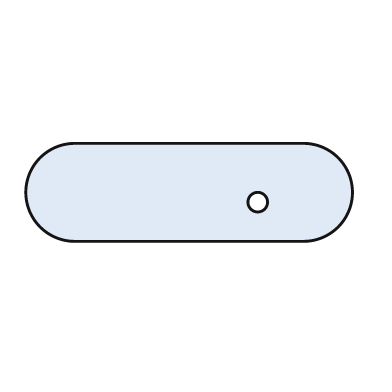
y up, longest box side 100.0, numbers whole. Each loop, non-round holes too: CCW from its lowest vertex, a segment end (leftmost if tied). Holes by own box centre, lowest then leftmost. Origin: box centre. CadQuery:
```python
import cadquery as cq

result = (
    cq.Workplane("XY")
    .moveTo(-35.0, -15.0)
    .lineTo(35.0, -15.0)
    .threePointArc((50.0, 0.0), (35.0, 15.0))
    .lineTo(-35.0, 15.0)
    .threePointArc((-50.0, 0.0), (-35.0, -15.0))
    .close()
    .moveTo(21.0, -3.0)
    .circle(3.0)
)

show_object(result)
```